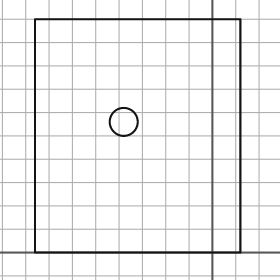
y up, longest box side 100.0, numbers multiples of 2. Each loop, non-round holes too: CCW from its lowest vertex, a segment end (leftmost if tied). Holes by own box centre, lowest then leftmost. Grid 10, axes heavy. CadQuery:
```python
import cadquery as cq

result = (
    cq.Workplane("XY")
    .moveTo(-76.0, 0.0)
    .lineTo(12.0, 0.0)
    .lineTo(12.0, 100.0)
    .lineTo(-76.0, 100.0)
    .close()
    .moveTo(-38.0, 56.0)
    .circle(6.0)
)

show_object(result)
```